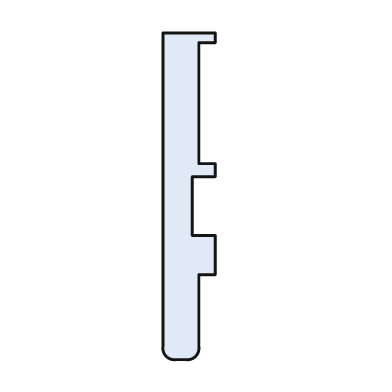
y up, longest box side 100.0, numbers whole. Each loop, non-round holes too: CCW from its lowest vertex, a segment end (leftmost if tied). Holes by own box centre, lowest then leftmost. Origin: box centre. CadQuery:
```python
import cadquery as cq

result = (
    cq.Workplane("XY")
    .moveTo(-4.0, -50.0)
    .lineTo(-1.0, -50.0)
    .threePointArc((2.0, -49.0), (3.0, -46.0))
    .lineTo(3.0, -24.0)
    .lineTo(8.0, -24.0)
    .lineTo(8.0, -12.0)
    .lineTo(1.0, -12.0)
    .lineTo(1.0, 6.0)
    .lineTo(8.0, 6.0)
    .lineTo(8.0, 10.0)
    .lineTo(3.0, 10.0)
    .lineTo(3.0, 47.0)
    .lineTo(8.0, 47.0)
    .lineTo(8.0, 50.0)
    .lineTo(-8.0, 50.0)
    .lineTo(-8.0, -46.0)
    .threePointArc((-7.0, -49.0), (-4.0, -50.0))
    .close()
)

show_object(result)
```